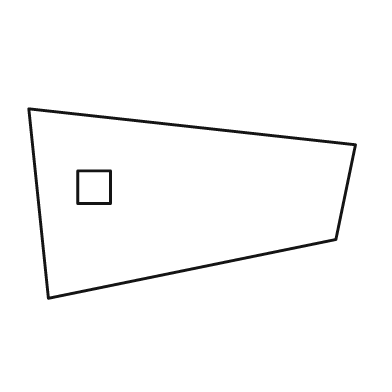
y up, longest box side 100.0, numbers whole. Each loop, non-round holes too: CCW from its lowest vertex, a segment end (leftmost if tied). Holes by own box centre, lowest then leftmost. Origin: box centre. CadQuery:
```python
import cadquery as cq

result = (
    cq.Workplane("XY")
    .moveTo(-44.0, -29.0)
    .lineTo(44.0, -11.0)
    .lineTo(50.0, 18.0)
    .lineTo(-50.0, 29.0)
    .close()
    .moveTo(-35.0, 0.0)
    .lineTo(-25.0, 0.0)
    .lineTo(-25.0, 10.0)
    .lineTo(-35.0, 10.0)
    .close()
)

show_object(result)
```